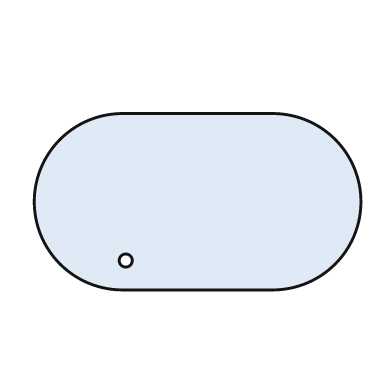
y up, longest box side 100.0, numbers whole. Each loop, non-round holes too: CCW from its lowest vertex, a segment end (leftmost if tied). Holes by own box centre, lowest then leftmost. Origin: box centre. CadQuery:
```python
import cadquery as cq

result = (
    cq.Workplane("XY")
    .moveTo(-23.0, -27.0)
    .lineTo(23.0, -27.0)
    .threePointArc((50.0, 0.0), (23.0, 27.0))
    .lineTo(-23.0, 27.0)
    .threePointArc((-50.0, 0.0), (-23.0, -27.0))
    .close()
    .moveTo(-22.0, -18.0)
    .circle(2.0)
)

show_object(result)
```